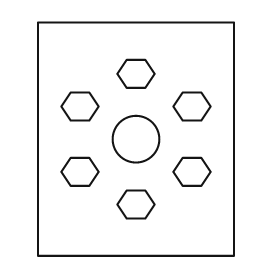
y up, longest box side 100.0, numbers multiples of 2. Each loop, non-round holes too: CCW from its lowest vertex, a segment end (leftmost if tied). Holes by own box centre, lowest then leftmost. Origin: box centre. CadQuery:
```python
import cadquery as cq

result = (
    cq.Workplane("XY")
    .moveTo(-42.0, -50.0)
    .lineTo(42.0, -50.0)
    .lineTo(42.0, 50.0)
    .lineTo(-42.0, 50.0)
    .close()
    .moveTo(-4.0, -34.0)
    .lineTo(4.0, -34.0)
    .lineTo(8.0, -28.0)
    .lineTo(4.0, -22.0)
    .lineTo(-4.0, -22.0)
    .lineTo(-8.0, -28.0)
    .close()
    .moveTo(-28.0, -20.0)
    .lineTo(-20.0, -20.0)
    .lineTo(-16.0, -14.0)
    .lineTo(-20.0, -8.0)
    .lineTo(-28.0, -8.0)
    .lineTo(-32.0, -14.0)
    .close()
    .moveTo(20.0, -20.0)
    .lineTo(28.0, -20.0)
    .lineTo(32.0, -14.0)
    .lineTo(28.0, -8.0)
    .lineTo(20.0, -8.0)
    .lineTo(16.0, -14.0)
    .close()
    .moveTo(0.0, 0.0)
    .circle(10.0)
    .moveTo(-28.0, 8.0)
    .lineTo(-20.0, 8.0)
    .lineTo(-16.0, 14.0)
    .lineTo(-20.0, 20.0)
    .lineTo(-28.0, 20.0)
    .lineTo(-32.0, 14.0)
    .close()
    .moveTo(20.0, 8.0)
    .lineTo(28.0, 8.0)
    .lineTo(32.0, 14.0)
    .lineTo(28.0, 20.0)
    .lineTo(20.0, 20.0)
    .lineTo(16.0, 14.0)
    .close()
    .moveTo(-4.0, 22.0)
    .lineTo(4.0, 22.0)
    .lineTo(8.0, 28.0)
    .lineTo(4.0, 34.0)
    .lineTo(-4.0, 34.0)
    .lineTo(-8.0, 28.0)
    .close()
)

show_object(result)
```